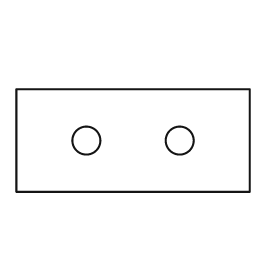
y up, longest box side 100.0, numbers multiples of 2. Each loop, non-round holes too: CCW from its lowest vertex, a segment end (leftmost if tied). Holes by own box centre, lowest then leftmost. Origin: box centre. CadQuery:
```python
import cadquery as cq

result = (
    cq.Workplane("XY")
    .moveTo(-50.0, -22.0)
    .lineTo(50.0, -22.0)
    .lineTo(50.0, 22.0)
    .lineTo(-50.0, 22.0)
    .close()
    .moveTo(-20.0, 0.0)
    .circle(6.0)
    .moveTo(20.0, 0.0)
    .circle(6.0)
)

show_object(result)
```